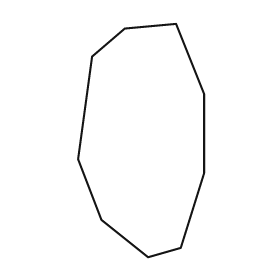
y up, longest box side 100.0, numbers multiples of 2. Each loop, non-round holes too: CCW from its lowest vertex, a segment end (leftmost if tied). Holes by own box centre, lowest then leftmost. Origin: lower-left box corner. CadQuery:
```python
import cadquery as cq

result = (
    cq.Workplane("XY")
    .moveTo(30.0, 0.0)
    .lineTo(44.0, 4.0)
    .lineTo(54.0, 36.0)
    .lineTo(54.0, 70.0)
    .lineTo(42.0, 100.0)
    .lineTo(20.0, 98.0)
    .lineTo(6.0, 86.0)
    .lineTo(0.0, 42.0)
    .lineTo(10.0, 16.0)
    .close()
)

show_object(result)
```